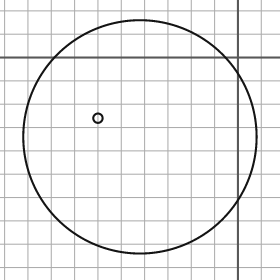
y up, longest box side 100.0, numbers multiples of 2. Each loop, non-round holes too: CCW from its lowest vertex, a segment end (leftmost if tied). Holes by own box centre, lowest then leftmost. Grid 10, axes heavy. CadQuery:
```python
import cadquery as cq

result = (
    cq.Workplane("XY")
    .moveTo(-42.0, -34.0)
    .circle(50.0)
    .moveTo(-60.0, -26.0)
    .circle(2.0)
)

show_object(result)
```